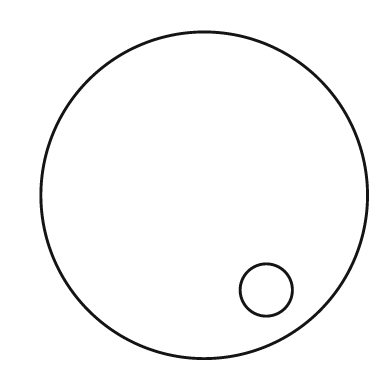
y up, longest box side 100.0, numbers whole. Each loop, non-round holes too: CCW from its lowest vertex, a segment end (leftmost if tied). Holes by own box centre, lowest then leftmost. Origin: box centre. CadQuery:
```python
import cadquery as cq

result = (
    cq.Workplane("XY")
    .moveTo(0.0, 0.0)
    .circle(50.0)
    .moveTo(19.0, -29.0)
    .circle(8.0)
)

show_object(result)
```